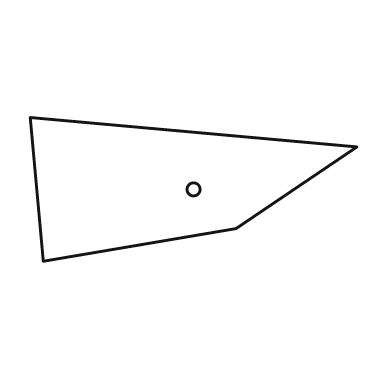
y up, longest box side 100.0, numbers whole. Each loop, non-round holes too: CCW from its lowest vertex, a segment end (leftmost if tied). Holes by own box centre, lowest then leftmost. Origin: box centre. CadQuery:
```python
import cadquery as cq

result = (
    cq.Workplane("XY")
    .moveTo(-46.0, -22.0)
    .lineTo(13.0, -12.0)
    .lineTo(50.0, 13.0)
    .lineTo(-50.0, 22.0)
    .close()
    .moveTo(0.0, 0.0)
    .circle(2.0)
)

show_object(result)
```